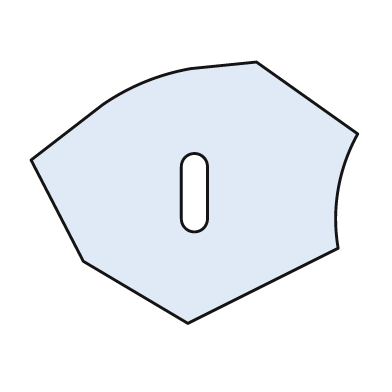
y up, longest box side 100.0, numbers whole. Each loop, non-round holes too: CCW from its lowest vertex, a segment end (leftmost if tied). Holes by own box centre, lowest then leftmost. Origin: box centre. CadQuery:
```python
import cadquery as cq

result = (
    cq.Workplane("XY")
    .moveTo(-2.0, -40.0)
    .lineTo(44.0, -17.0)
    .threePointArc((44.0, 1.0), (50.0, 18.0))
    .lineTo(19.0, 40.0)
    .lineTo(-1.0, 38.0)
    .threePointArc((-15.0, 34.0), (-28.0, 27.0))
    .lineTo(-50.0, 10.0)
    .lineTo(-34.0, -21.0)
    .close()
    .moveTo(-4.0, -8.0)
    .threePointArc((0.0, -12.0), (4.0, -8.0))
    .lineTo(4.0, 8.0)
    .threePointArc((0.0, 12.0), (-4.0, 8.0))
    .close()
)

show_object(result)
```